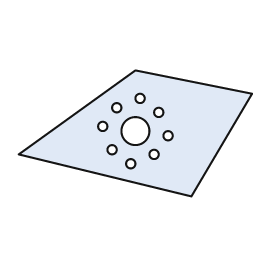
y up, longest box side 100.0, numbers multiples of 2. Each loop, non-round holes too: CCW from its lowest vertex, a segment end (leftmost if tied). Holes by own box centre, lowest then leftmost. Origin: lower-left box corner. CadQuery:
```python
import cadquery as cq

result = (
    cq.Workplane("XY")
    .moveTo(74.0, 0.0)
    .lineTo(100.0, 44.0)
    .lineTo(50.0, 54.0)
    .lineTo(0.0, 18.0)
    .close()
    .moveTo(48.0, 14.0)
    .circle(2.0)
    .moveTo(58.0, 18.0)
    .circle(2.0)
    .moveTo(40.0, 20.0)
    .circle(2.0)
    .moveTo(64.0, 26.0)
    .circle(2.0)
    .moveTo(50.0, 28.0)
    .circle(6.0)
    .moveTo(36.0, 30.0)
    .circle(2.0)
    .moveTo(60.0, 36.0)
    .circle(2.0)
    .moveTo(42.0, 38.0)
    .circle(2.0)
    .moveTo(52.0, 42.0)
    .circle(2.0)
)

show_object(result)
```